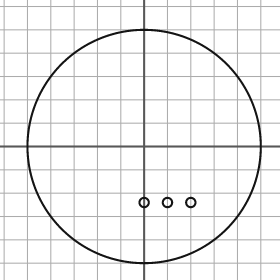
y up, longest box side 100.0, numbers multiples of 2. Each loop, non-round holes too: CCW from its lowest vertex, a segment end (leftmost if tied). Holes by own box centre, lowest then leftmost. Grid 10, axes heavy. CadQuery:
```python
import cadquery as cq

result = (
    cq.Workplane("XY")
    .moveTo(0.0, 0.0)
    .circle(50.0)
    .moveTo(0.0, -24.0)
    .circle(2.0)
    .moveTo(10.0, -24.0)
    .circle(2.0)
    .moveTo(20.0, -24.0)
    .circle(2.0)
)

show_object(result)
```